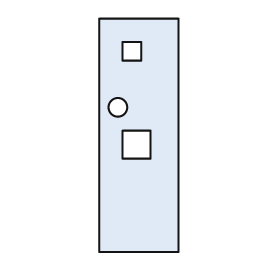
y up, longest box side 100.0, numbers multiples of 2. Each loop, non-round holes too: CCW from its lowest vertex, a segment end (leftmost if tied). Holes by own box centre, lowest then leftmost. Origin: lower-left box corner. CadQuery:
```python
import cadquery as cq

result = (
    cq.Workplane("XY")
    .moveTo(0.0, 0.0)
    .lineTo(34.0, 0.0)
    .lineTo(34.0, 100.0)
    .lineTo(0.0, 100.0)
    .close()
    .moveTo(10.0, 40.0)
    .lineTo(22.0, 40.0)
    .lineTo(22.0, 52.0)
    .lineTo(10.0, 52.0)
    .close()
    .moveTo(8.0, 62.0)
    .circle(4.0)
    .moveTo(10.0, 82.0)
    .lineTo(18.0, 82.0)
    .lineTo(18.0, 90.0)
    .lineTo(10.0, 90.0)
    .close()
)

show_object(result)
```